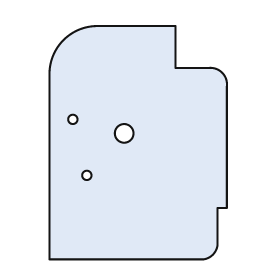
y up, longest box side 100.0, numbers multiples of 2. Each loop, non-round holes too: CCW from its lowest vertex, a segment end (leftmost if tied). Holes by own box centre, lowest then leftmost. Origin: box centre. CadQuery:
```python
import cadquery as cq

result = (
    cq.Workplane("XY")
    .moveTo(-38.0, -50.0)
    .lineTo(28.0, -50.0)
    .threePointArc((32.0, -48.0), (34.0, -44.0))
    .lineTo(34.0, -28.0)
    .lineTo(38.0, -28.0)
    .lineTo(38.0, 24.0)
    .threePointArc((36.0, 30.0), (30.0, 32.0))
    .lineTo(16.0, 32.0)
    .lineTo(16.0, 50.0)
    .lineTo(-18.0, 50.0)
    .threePointArc((-32.0, 44.0), (-38.0, 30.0))
    .close()
    .moveTo(-22.0, -14.0)
    .circle(2.0)
    .moveTo(-6.0, 4.0)
    .circle(4.0)
    .moveTo(-28.0, 10.0)
    .circle(2.0)
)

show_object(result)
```